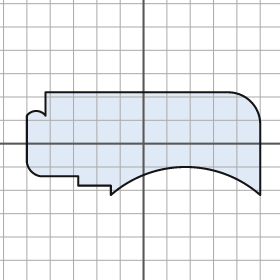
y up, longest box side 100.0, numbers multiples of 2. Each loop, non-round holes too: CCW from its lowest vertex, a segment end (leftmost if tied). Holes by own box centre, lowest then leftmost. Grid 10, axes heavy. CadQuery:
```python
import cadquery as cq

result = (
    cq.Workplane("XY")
    .moveTo(-14.0, -22.0)
    .threePointArc((18.0, -10.0), (50.0, -22.0))
    .lineTo(50.0, 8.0)
    .threePointArc((46.0, 18.0), (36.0, 22.0))
    .lineTo(-42.0, 22.0)
    .lineTo(-42.0, 12.0)
    .threePointArc((-46.0, 14.0), (-50.0, 12.0))
    .lineTo(-50.0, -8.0)
    .threePointArc((-48.0, -12.0), (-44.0, -14.0))
    .lineTo(-28.0, -14.0)
    .lineTo(-28.0, -18.0)
    .lineTo(-14.0, -18.0)
    .close()
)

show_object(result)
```